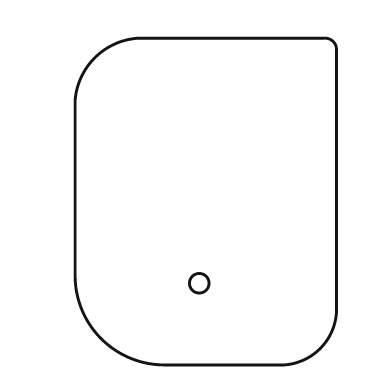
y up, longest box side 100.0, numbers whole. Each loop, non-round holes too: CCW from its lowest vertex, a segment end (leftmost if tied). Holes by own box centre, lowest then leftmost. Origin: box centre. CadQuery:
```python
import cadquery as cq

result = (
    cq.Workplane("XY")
    .moveTo(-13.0, -50.0)
    .lineTo(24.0, -50.0)
    .threePointArc((35.0, -45.0), (40.0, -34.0))
    .lineTo(40.0, 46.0)
    .threePointArc((39.0, 49.0), (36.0, 50.0))
    .lineTo(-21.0, 50.0)
    .threePointArc((-34.0, 44.0), (-40.0, 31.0))
    .lineTo(-40.0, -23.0)
    .threePointArc((-32.0, -42.0), (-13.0, -50.0))
    .close()
    .moveTo(-2.0, -25.0)
    .circle(3.0)
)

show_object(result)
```